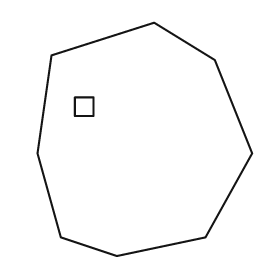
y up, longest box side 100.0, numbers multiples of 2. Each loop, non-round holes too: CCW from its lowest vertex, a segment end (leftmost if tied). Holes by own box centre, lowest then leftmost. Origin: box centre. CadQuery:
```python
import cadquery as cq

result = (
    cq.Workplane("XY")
    .moveTo(-12.0, -50.0)
    .lineTo(26.0, -42.0)
    .lineTo(46.0, -6.0)
    .lineTo(30.0, 34.0)
    .lineTo(4.0, 50.0)
    .lineTo(-40.0, 36.0)
    .lineTo(-46.0, -6.0)
    .lineTo(-36.0, -42.0)
    .close()
    .moveTo(-30.0, 10.0)
    .lineTo(-22.0, 10.0)
    .lineTo(-22.0, 18.0)
    .lineTo(-30.0, 18.0)
    .close()
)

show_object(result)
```